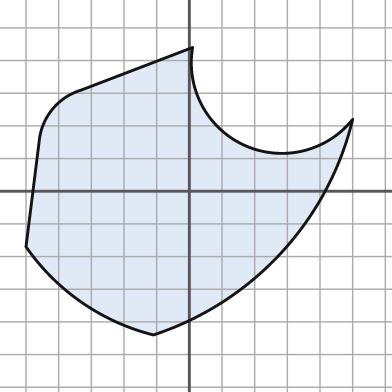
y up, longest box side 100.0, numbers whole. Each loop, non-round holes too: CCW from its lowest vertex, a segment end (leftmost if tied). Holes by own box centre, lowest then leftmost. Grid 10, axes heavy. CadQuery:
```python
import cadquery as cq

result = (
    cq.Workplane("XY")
    .moveTo(-11.0, -44.0)
    .threePointArc((28.0, -19.0), (50.0, 22.0))
    .threePointArc((17.0, 14.0), (1.0, 44.0))
    .lineTo(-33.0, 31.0)
    .threePointArc((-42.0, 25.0), (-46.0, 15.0))
    .lineTo(-50.0, -17.0)
    .threePointArc((-33.0, -34.0), (-11.0, -44.0))
    .close()
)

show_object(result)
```